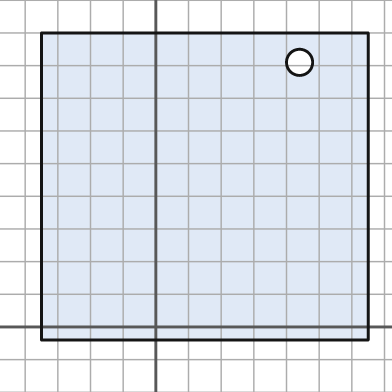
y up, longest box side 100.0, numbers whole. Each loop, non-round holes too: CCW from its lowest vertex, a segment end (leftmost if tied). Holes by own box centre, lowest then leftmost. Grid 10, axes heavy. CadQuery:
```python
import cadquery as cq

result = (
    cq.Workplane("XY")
    .moveTo(-35.0, -4.0)
    .lineTo(65.0, -4.0)
    .lineTo(65.0, 90.0)
    .lineTo(-35.0, 90.0)
    .close()
    .moveTo(44.0, 81.0)
    .circle(4.0)
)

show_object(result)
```